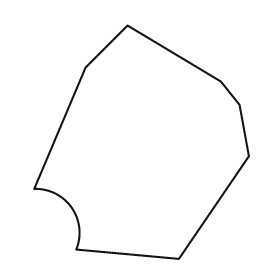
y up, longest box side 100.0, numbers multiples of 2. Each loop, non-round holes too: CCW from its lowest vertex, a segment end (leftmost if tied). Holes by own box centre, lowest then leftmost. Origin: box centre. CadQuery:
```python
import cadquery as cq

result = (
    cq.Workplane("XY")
    .moveTo(16.0, -50.0)
    .lineTo(46.0, -6.0)
    .lineTo(42.0, 16.0)
    .lineTo(34.0, 26.0)
    .lineTo(-6.0, 50.0)
    .lineTo(-24.0, 32.0)
    .lineTo(-46.0, -20.0)
    .threePointArc((-30.0, -28.0), (-28.0, -46.0))
    .close()
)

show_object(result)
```